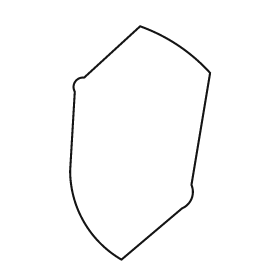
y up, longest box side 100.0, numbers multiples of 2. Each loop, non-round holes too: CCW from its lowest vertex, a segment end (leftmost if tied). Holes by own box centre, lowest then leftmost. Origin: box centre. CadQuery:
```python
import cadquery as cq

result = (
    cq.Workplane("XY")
    .moveTo(-8.0, -50.0)
    .lineTo(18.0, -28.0)
    .threePointArc((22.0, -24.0), (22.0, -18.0))
    .lineTo(30.0, 30.0)
    .threePointArc((16.0, 42.0), (0.0, 50.0))
    .lineTo(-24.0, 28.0)
    .threePointArc((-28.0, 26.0), (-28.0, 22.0))
    .lineTo(-30.0, -12.0)
    .threePointArc((-24.0, -34.0), (-8.0, -50.0))
    .close()
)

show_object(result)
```